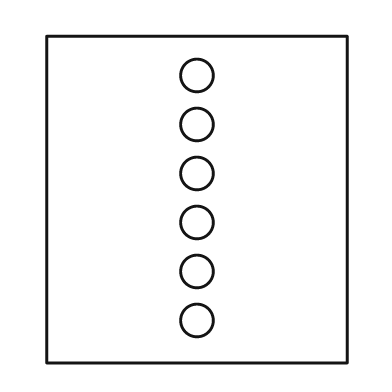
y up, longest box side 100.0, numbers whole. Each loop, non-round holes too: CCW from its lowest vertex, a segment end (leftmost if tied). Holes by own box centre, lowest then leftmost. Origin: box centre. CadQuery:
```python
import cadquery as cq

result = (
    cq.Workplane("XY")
    .moveTo(-46.0, -50.0)
    .lineTo(46.0, -50.0)
    .lineTo(46.0, 50.0)
    .lineTo(-46.0, 50.0)
    .close()
    .moveTo(0.0, -37.0)
    .circle(5.0)
    .moveTo(0.0, -22.0)
    .circle(5.0)
    .moveTo(0.0, -7.0)
    .circle(5.0)
    .moveTo(0.0, 8.0)
    .circle(5.0)
    .moveTo(0.0, 23.0)
    .circle(5.0)
    .moveTo(0.0, 38.0)
    .circle(5.0)
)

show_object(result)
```